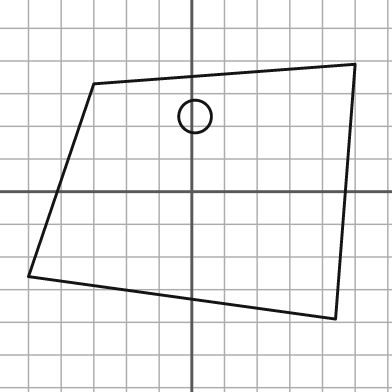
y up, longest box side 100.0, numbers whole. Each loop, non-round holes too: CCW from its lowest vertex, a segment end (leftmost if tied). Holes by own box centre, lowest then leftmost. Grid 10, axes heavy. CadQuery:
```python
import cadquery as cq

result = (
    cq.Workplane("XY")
    .moveTo(44.0, -39.0)
    .lineTo(50.0, 39.0)
    .lineTo(-30.0, 33.0)
    .lineTo(-50.0, -26.0)
    .close()
    .moveTo(1.0, 23.0)
    .circle(5.0)
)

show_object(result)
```